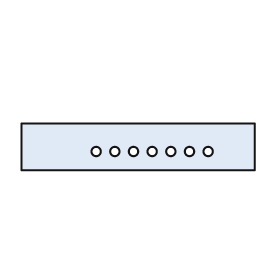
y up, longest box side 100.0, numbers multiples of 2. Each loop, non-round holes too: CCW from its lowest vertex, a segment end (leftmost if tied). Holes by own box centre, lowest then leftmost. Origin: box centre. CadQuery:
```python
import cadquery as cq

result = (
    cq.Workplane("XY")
    .moveTo(-50.0, -10.0)
    .lineTo(50.0, -10.0)
    .lineTo(50.0, 10.0)
    .lineTo(-50.0, 10.0)
    .close()
    .moveTo(-18.0, -2.0)
    .circle(2.0)
    .moveTo(-10.0, -2.0)
    .circle(2.0)
    .moveTo(-2.0, -2.0)
    .circle(2.0)
    .moveTo(6.0, -2.0)
    .circle(2.0)
    .moveTo(14.0, -2.0)
    .circle(2.0)
    .moveTo(22.0, -2.0)
    .circle(2.0)
    .moveTo(30.0, -2.0)
    .circle(2.0)
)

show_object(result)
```